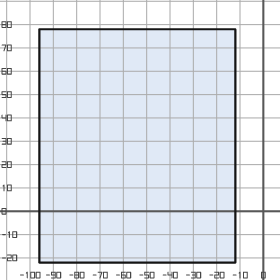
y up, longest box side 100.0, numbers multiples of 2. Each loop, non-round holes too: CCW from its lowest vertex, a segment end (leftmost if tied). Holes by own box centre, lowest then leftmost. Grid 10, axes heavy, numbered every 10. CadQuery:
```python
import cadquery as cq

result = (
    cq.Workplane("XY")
    .moveTo(-96.0, -22.0)
    .lineTo(-12.0, -22.0)
    .lineTo(-12.0, 78.0)
    .lineTo(-96.0, 78.0)
    .close()
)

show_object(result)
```